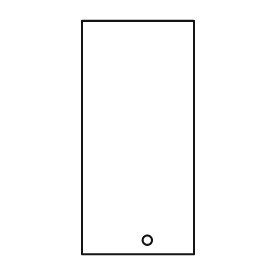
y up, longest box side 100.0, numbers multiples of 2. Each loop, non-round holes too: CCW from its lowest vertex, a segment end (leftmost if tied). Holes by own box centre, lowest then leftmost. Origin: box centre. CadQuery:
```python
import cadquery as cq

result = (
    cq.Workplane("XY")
    .moveTo(-24.0, -50.0)
    .lineTo(24.0, -50.0)
    .lineTo(24.0, 50.0)
    .lineTo(-24.0, 50.0)
    .close()
    .moveTo(4.0, -44.0)
    .circle(2.0)
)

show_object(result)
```